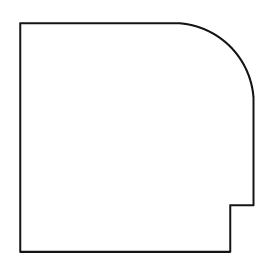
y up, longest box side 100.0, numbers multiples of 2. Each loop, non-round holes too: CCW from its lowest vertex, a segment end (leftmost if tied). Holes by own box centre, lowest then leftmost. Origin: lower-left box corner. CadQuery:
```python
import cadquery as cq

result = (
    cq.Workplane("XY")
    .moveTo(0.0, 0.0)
    .lineTo(90.0, 0.0)
    .lineTo(90.0, 20.0)
    .lineTo(100.0, 20.0)
    .lineTo(100.0, 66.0)
    .threePointArc((90.0, 88.0), (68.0, 98.0))
    .lineTo(0.0, 98.0)
    .close()
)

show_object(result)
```